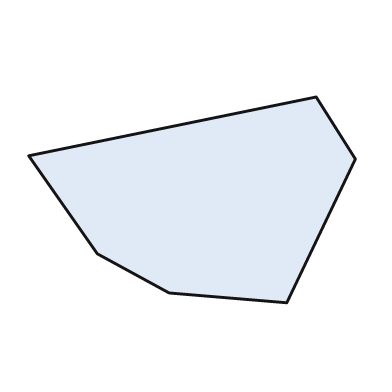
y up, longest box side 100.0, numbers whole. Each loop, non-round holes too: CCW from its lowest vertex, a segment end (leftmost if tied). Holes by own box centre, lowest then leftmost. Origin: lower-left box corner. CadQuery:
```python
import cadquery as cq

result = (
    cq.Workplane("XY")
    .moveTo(79.0, 0.0)
    .lineTo(100.0, 44.0)
    .lineTo(88.0, 63.0)
    .lineTo(0.0, 45.0)
    .lineTo(21.0, 15.0)
    .lineTo(43.0, 3.0)
    .close()
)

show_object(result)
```